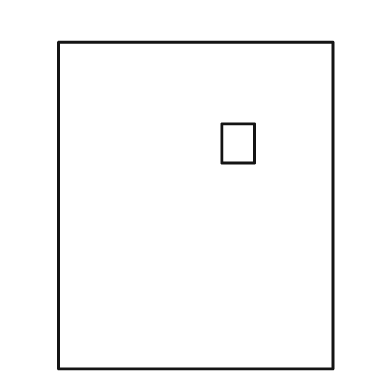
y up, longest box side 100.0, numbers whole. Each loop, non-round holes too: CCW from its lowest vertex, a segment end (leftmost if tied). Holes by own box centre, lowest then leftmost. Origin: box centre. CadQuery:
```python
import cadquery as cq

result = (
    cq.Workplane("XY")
    .moveTo(-42.0, -50.0)
    .lineTo(42.0, -50.0)
    .lineTo(42.0, 50.0)
    .lineTo(-42.0, 50.0)
    .close()
    .moveTo(8.0, 13.0)
    .lineTo(18.0, 13.0)
    .lineTo(18.0, 25.0)
    .lineTo(8.0, 25.0)
    .close()
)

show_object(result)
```